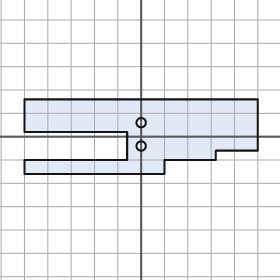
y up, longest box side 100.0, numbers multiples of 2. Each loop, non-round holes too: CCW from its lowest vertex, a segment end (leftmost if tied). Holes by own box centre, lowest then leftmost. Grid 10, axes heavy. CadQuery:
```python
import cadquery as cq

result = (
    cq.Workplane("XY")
    .moveTo(-50.0, -16.0)
    .lineTo(10.0, -16.0)
    .lineTo(10.0, -10.0)
    .lineTo(32.0, -10.0)
    .lineTo(32.0, -6.0)
    .lineTo(50.0, -6.0)
    .lineTo(50.0, 16.0)
    .lineTo(-50.0, 16.0)
    .lineTo(-50.0, 2.0)
    .lineTo(-6.0, 2.0)
    .lineTo(-6.0, -10.0)
    .lineTo(-50.0, -10.0)
    .close()
    .moveTo(0.0, -4.0)
    .circle(2.0)
    .moveTo(0.0, 6.0)
    .circle(2.0)
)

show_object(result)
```